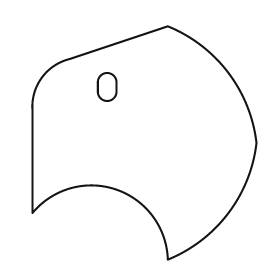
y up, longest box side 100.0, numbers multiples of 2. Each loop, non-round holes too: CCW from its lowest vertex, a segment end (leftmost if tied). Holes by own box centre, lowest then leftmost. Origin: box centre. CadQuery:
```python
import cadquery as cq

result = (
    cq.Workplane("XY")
    .moveTo(10.0, -50.0)
    .threePointArc((36.0, -30.0), (48.0, 0.0))
    .threePointArc((36.0, 30.0), (10.0, 50.0))
    .lineTo(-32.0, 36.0)
    .threePointArc((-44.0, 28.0), (-48.0, 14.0))
    .lineTo(-48.0, -30.0)
    .threePointArc((-12.0, -20.0), (10.0, -50.0))
    .close()
    .moveTo(-20.0, 22.0)
    .threePointArc((-16.0, 18.0), (-12.0, 22.0))
    .lineTo(-12.0, 26.0)
    .threePointArc((-16.0, 30.0), (-20.0, 26.0))
    .close()
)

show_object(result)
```